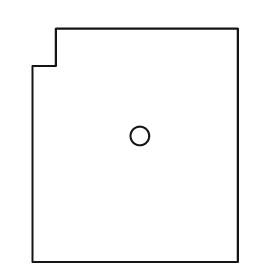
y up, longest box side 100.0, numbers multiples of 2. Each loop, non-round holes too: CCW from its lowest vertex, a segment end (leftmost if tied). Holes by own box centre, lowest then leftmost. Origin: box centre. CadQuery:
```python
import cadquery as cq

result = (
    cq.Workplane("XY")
    .moveTo(-44.0, -50.0)
    .lineTo(44.0, -50.0)
    .lineTo(44.0, 50.0)
    .lineTo(-34.0, 50.0)
    .lineTo(-34.0, 34.0)
    .lineTo(-44.0, 34.0)
    .close()
    .moveTo(2.0, 4.0)
    .circle(4.0)
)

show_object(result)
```